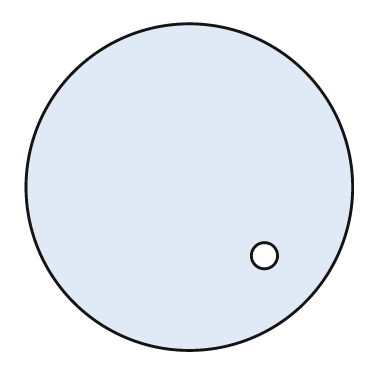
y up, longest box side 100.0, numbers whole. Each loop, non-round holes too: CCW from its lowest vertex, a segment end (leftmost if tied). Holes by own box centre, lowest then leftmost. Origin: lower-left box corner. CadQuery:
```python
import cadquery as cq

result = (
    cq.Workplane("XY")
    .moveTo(50.0, 50.0)
    .circle(50.0)
    .moveTo(73.0, 29.0)
    .circle(4.0)
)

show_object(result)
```